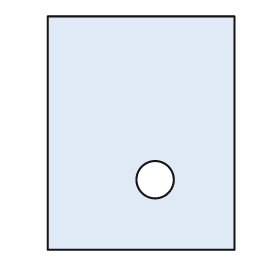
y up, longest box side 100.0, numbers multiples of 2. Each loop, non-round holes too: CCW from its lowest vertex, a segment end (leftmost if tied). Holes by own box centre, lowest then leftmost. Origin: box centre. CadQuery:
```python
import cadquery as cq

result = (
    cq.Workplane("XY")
    .moveTo(-40.0, -50.0)
    .lineTo(40.0, -50.0)
    .lineTo(40.0, 50.0)
    .lineTo(-40.0, 50.0)
    .close()
    .moveTo(6.0, -20.0)
    .circle(8.0)
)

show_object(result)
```